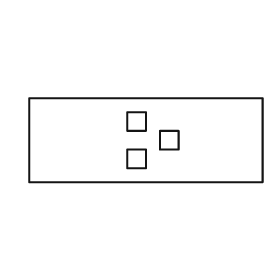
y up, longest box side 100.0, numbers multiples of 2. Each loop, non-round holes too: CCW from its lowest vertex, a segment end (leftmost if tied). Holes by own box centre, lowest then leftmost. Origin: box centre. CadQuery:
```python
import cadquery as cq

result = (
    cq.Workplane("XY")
    .moveTo(-50.0, -18.0)
    .lineTo(50.0, -18.0)
    .lineTo(50.0, 18.0)
    .lineTo(-50.0, 18.0)
    .close()
    .moveTo(-8.0, -12.0)
    .lineTo(0.0, -12.0)
    .lineTo(0.0, -4.0)
    .lineTo(-8.0, -4.0)
    .close()
    .moveTo(6.0, -4.0)
    .lineTo(14.0, -4.0)
    .lineTo(14.0, 4.0)
    .lineTo(6.0, 4.0)
    .close()
    .moveTo(-8.0, 4.0)
    .lineTo(0.0, 4.0)
    .lineTo(0.0, 12.0)
    .lineTo(-8.0, 12.0)
    .close()
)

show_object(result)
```